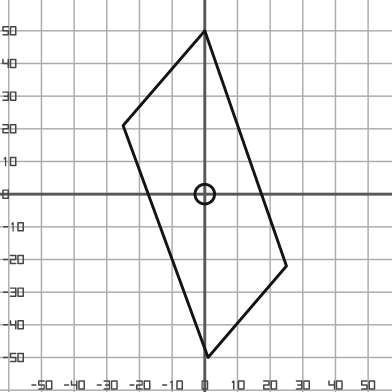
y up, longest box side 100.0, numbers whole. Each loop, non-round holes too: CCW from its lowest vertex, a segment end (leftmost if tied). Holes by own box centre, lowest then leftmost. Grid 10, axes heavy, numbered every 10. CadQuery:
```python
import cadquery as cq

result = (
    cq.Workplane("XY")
    .moveTo(1.0, -50.0)
    .lineTo(25.0, -22.0)
    .lineTo(0.0, 50.0)
    .lineTo(-25.0, 21.0)
    .close()
    .moveTo(0.0, 0.0)
    .circle(3.0)
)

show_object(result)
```